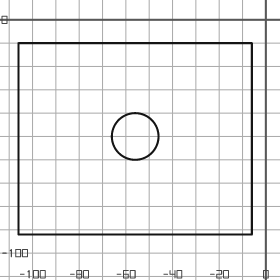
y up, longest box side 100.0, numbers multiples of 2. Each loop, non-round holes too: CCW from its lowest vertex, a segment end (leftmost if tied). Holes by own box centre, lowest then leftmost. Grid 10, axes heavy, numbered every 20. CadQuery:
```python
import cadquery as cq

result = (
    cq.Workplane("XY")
    .moveTo(-106.0, -92.0)
    .lineTo(-6.0, -92.0)
    .lineTo(-6.0, -10.0)
    .lineTo(-106.0, -10.0)
    .close()
    .moveTo(-56.0, -50.0)
    .circle(10.0)
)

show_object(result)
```